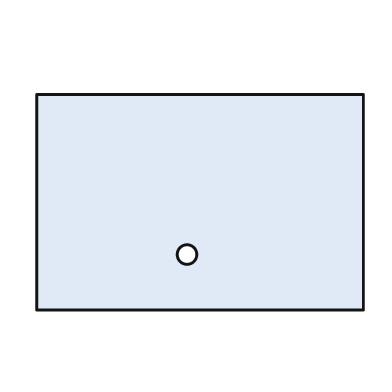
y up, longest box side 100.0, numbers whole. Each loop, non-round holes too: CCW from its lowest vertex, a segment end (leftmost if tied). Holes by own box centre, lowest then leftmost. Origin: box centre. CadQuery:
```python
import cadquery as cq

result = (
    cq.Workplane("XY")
    .moveTo(-50.0, -33.0)
    .lineTo(50.0, -33.0)
    .lineTo(50.0, 33.0)
    .lineTo(-50.0, 33.0)
    .close()
    .moveTo(-4.0, -16.0)
    .circle(3.0)
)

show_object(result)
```